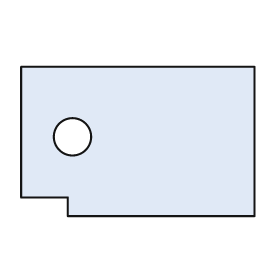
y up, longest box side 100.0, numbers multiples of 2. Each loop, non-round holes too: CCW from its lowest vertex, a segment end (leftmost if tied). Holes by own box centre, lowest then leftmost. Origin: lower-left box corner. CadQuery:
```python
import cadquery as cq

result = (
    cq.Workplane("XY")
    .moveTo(20.0, 0.0)
    .lineTo(100.0, 0.0)
    .lineTo(100.0, 64.0)
    .lineTo(0.0, 64.0)
    .lineTo(0.0, 8.0)
    .lineTo(20.0, 8.0)
    .close()
    .moveTo(22.0, 34.0)
    .circle(8.0)
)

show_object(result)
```